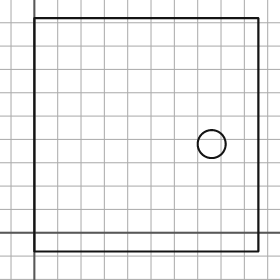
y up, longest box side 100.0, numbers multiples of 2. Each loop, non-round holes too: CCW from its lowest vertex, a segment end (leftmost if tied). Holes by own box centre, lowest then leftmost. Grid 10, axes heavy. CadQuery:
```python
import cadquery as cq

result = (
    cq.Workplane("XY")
    .moveTo(0.0, -8.0)
    .lineTo(96.0, -8.0)
    .lineTo(96.0, 92.0)
    .lineTo(0.0, 92.0)
    .close()
    .moveTo(76.0, 38.0)
    .circle(6.0)
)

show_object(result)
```